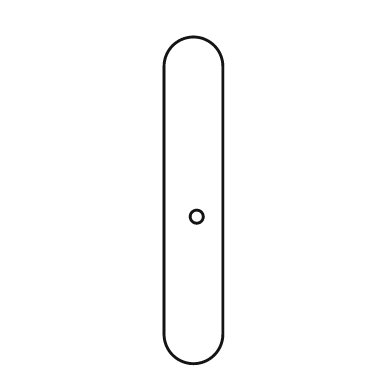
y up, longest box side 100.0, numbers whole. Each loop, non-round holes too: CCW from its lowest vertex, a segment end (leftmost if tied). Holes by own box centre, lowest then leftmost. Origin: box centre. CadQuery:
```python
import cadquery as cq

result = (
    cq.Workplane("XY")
    .moveTo(-9.0, -41.0)
    .threePointArc((0.0, -50.0), (9.0, -41.0))
    .lineTo(9.0, 41.0)
    .threePointArc((0.0, 50.0), (-9.0, 41.0))
    .close()
    .moveTo(1.0, -5.0)
    .circle(2.0)
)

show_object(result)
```